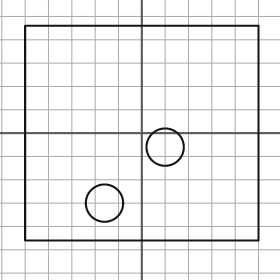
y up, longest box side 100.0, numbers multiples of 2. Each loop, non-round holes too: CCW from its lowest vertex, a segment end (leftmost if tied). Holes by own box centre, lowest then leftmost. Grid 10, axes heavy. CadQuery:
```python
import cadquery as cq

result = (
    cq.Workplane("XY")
    .moveTo(-50.0, -46.0)
    .lineTo(50.0, -46.0)
    .lineTo(50.0, 46.0)
    .lineTo(-50.0, 46.0)
    .close()
    .moveTo(-16.0, -30.0)
    .circle(8.0)
    .moveTo(10.0, -6.0)
    .circle(8.0)
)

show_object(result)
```